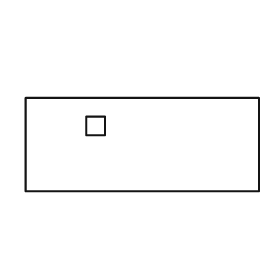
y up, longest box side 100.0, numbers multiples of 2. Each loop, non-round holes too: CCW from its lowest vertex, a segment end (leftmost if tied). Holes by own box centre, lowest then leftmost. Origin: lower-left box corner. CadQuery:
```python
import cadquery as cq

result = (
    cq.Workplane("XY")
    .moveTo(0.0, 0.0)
    .lineTo(100.0, 0.0)
    .lineTo(100.0, 40.0)
    .lineTo(0.0, 40.0)
    .close()
    .moveTo(26.0, 24.0)
    .lineTo(34.0, 24.0)
    .lineTo(34.0, 32.0)
    .lineTo(26.0, 32.0)
    .close()
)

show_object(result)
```